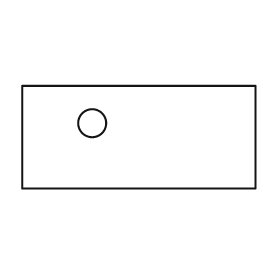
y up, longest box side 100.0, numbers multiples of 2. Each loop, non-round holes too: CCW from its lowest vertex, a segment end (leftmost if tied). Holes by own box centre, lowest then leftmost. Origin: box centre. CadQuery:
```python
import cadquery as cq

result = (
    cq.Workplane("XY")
    .moveTo(-50.0, -22.0)
    .lineTo(50.0, -22.0)
    .lineTo(50.0, 22.0)
    .lineTo(-50.0, 22.0)
    .close()
    .moveTo(-20.0, 6.0)
    .circle(6.0)
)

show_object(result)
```